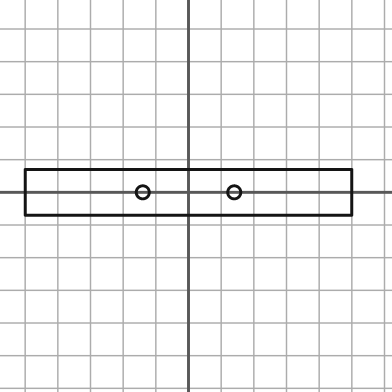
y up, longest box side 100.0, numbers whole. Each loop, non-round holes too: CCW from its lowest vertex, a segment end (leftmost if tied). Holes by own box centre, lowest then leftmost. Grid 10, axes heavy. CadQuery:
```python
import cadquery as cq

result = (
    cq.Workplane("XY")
    .moveTo(-50.0, -7.0)
    .lineTo(50.0, -7.0)
    .lineTo(50.0, 7.0)
    .lineTo(-50.0, 7.0)
    .close()
    .moveTo(-14.0, 0.0)
    .circle(2.0)
    .moveTo(14.0, 0.0)
    .circle(2.0)
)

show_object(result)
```